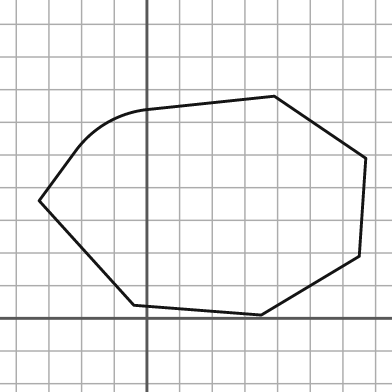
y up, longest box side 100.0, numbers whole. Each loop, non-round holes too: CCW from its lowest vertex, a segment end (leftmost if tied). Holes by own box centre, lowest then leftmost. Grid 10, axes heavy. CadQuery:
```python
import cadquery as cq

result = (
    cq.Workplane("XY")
    .moveTo(35.0, 1.0)
    .lineTo(65.0, 19.0)
    .lineTo(67.0, 49.0)
    .lineTo(39.0, 68.0)
    .lineTo(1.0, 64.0)
    .threePointArc((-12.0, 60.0), (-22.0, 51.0))
    .lineTo(-33.0, 36.0)
    .lineTo(-4.0, 4.0)
    .close()
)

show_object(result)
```